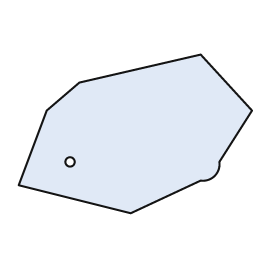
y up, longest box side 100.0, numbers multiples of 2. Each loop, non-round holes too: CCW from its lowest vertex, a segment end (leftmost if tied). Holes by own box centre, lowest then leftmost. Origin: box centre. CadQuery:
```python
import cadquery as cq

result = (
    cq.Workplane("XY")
    .moveTo(-2.0, -34.0)
    .lineTo(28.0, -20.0)
    .threePointArc((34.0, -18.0), (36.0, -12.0))
    .lineTo(50.0, 10.0)
    .lineTo(28.0, 34.0)
    .lineTo(-24.0, 22.0)
    .lineTo(-38.0, 10.0)
    .lineTo(-50.0, -22.0)
    .close()
    .moveTo(-28.0, -12.0)
    .circle(2.0)
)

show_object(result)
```